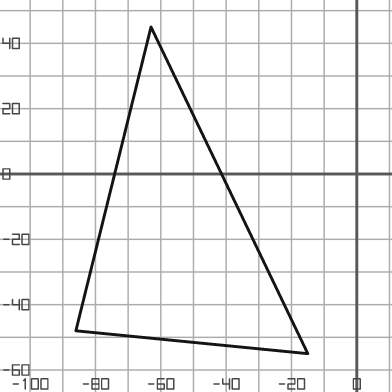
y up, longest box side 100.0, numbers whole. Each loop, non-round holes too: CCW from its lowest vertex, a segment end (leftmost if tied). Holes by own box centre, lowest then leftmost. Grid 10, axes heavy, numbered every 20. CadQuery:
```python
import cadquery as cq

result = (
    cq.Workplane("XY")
    .moveTo(-15.0, -55.0)
    .lineTo(-63.0, 45.0)
    .lineTo(-86.0, -48.0)
    .close()
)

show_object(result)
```